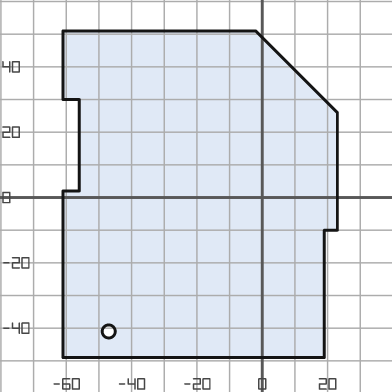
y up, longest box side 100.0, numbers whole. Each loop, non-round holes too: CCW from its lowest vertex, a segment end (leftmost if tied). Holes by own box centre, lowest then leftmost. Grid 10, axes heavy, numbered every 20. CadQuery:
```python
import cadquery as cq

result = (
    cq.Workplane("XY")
    .moveTo(-61.0, -49.0)
    .lineTo(19.0, -49.0)
    .lineTo(19.0, -10.0)
    .lineTo(23.0, -10.0)
    .lineTo(23.0, 26.0)
    .lineTo(-2.0, 51.0)
    .lineTo(-61.0, 51.0)
    .lineTo(-61.0, 30.0)
    .lineTo(-56.0, 30.0)
    .lineTo(-56.0, 2.0)
    .lineTo(-61.0, 2.0)
    .close()
    .moveTo(-47.0, -41.0)
    .circle(2.0)
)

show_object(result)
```